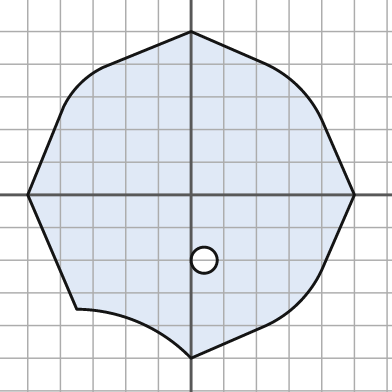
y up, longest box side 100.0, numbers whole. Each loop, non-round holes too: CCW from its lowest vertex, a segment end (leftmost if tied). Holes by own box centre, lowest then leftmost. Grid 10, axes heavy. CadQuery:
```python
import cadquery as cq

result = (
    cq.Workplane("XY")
    .moveTo(0.0, -50.0)
    .lineTo(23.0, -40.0)
    .threePointArc((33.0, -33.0), (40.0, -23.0))
    .lineTo(50.0, 0.0)
    .lineTo(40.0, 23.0)
    .threePointArc((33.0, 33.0), (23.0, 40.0))
    .lineTo(0.0, 50.0)
    .lineTo(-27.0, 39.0)
    .threePointArc((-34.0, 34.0), (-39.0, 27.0))
    .lineTo(-50.0, 0.0)
    .lineTo(-35.0, -35.0)
    .threePointArc((-16.0, -39.0), (0.0, -50.0))
    .close()
    .moveTo(4.0, -20.0)
    .circle(4.0)
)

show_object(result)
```